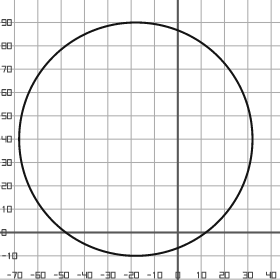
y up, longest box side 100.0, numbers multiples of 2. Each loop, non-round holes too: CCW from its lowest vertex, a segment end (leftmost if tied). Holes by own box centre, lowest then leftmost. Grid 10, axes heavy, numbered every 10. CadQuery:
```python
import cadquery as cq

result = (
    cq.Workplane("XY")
    .moveTo(-18.0, 40.0)
    .circle(50.0)
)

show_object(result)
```